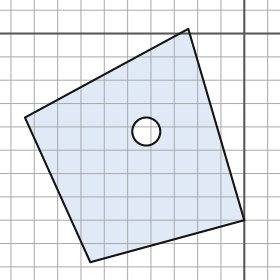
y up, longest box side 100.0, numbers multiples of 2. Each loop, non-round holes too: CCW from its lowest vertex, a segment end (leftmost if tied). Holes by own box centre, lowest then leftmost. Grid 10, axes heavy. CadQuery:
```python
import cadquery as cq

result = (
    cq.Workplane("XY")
    .moveTo(-66.0, -98.0)
    .lineTo(0.0, -80.0)
    .lineTo(-24.0, 2.0)
    .lineTo(-94.0, -36.0)
    .close()
    .moveTo(-42.0, -42.0)
    .circle(6.0)
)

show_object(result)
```